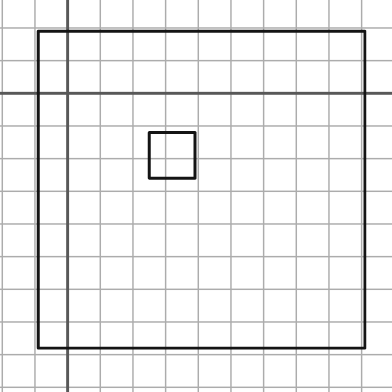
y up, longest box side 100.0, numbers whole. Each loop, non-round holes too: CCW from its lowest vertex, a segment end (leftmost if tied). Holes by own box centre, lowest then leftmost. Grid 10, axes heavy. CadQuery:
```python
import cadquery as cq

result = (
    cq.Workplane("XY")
    .moveTo(-9.0, -78.0)
    .lineTo(91.0, -78.0)
    .lineTo(91.0, 19.0)
    .lineTo(-9.0, 19.0)
    .close()
    .moveTo(25.0, -26.0)
    .lineTo(39.0, -26.0)
    .lineTo(39.0, -12.0)
    .lineTo(25.0, -12.0)
    .close()
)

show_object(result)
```